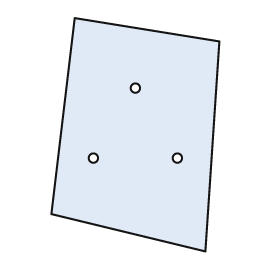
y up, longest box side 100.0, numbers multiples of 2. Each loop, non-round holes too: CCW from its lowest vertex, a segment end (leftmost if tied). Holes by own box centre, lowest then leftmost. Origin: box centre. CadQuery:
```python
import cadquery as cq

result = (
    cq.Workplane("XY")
    .moveTo(30.0, -50.0)
    .lineTo(36.0, 40.0)
    .lineTo(-26.0, 50.0)
    .lineTo(-36.0, -34.0)
    .close()
    .moveTo(-18.0, -10.0)
    .circle(2.0)
    .moveTo(18.0, -10.0)
    .circle(2.0)
    .moveTo(0.0, 20.0)
    .circle(2.0)
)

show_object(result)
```